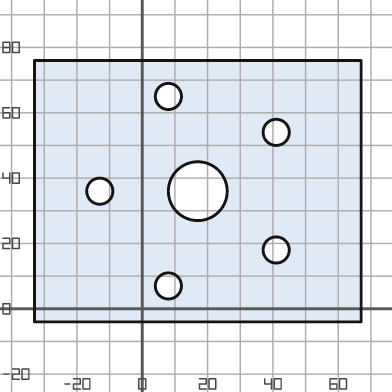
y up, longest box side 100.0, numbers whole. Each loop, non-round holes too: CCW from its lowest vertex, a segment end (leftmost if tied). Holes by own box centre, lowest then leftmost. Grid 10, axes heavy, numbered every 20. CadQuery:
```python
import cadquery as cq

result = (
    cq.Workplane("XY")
    .moveTo(-33.0, -4.0)
    .lineTo(67.0, -4.0)
    .lineTo(67.0, 76.0)
    .lineTo(-33.0, 76.0)
    .close()
    .moveTo(8.0, 7.0)
    .circle(4.0)
    .moveTo(41.0, 18.0)
    .circle(4.0)
    .moveTo(-13.0, 36.0)
    .circle(4.0)
    .moveTo(17.0, 36.0)
    .circle(9.0)
    .moveTo(41.0, 54.0)
    .circle(4.0)
    .moveTo(8.0, 65.0)
    .circle(4.0)
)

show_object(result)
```